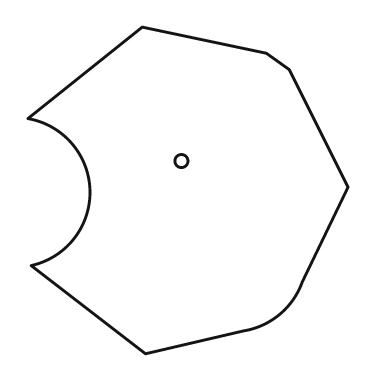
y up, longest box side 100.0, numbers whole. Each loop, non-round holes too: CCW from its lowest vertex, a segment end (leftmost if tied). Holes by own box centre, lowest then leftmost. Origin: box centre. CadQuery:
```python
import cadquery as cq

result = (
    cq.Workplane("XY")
    .moveTo(-13.0, -50.0)
    .lineTo(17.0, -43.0)
    .threePointArc((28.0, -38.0), (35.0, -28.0))
    .lineTo(49.0, 1.0)
    .lineTo(31.0, 37.0)
    .lineTo(24.0, 42.0)
    .lineTo(-14.0, 50.0)
    .lineTo(-49.0, 22.0)
    .threePointArc((-30.0, 0.0), (-48.0, -23.0))
    .close()
    .moveTo(-2.0, 9.0)
    .circle(2.0)
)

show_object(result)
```